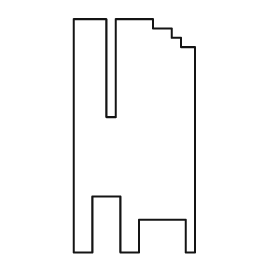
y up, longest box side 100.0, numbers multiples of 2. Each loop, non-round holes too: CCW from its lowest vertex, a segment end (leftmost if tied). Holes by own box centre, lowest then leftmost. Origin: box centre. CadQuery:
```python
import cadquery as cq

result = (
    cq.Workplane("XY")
    .moveTo(-26.0, -50.0)
    .lineTo(-18.0, -50.0)
    .lineTo(-18.0, -26.0)
    .lineTo(-6.0, -26.0)
    .lineTo(-6.0, -50.0)
    .lineTo(2.0, -50.0)
    .lineTo(2.0, -36.0)
    .lineTo(22.0, -36.0)
    .lineTo(22.0, -50.0)
    .lineTo(26.0, -50.0)
    .lineTo(26.0, 38.0)
    .lineTo(20.0, 38.0)
    .lineTo(20.0, 42.0)
    .lineTo(16.0, 42.0)
    .lineTo(16.0, 46.0)
    .lineTo(8.0, 46.0)
    .lineTo(8.0, 50.0)
    .lineTo(-8.0, 50.0)
    .lineTo(-8.0, 8.0)
    .lineTo(-12.0, 8.0)
    .lineTo(-12.0, 50.0)
    .lineTo(-26.0, 50.0)
    .close()
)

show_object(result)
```